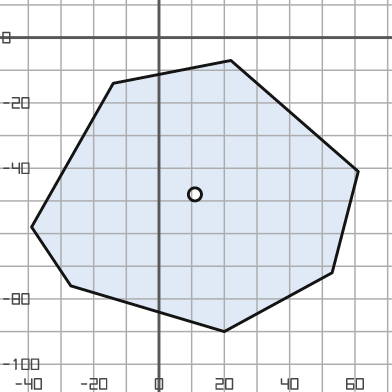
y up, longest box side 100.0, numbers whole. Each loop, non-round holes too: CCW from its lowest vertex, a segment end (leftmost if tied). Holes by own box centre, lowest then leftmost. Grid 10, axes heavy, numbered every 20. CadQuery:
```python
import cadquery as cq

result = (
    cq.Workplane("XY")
    .moveTo(20.0, -90.0)
    .lineTo(53.0, -72.0)
    .lineTo(61.0, -41.0)
    .lineTo(22.0, -7.0)
    .lineTo(-14.0, -14.0)
    .lineTo(-39.0, -58.0)
    .lineTo(-27.0, -76.0)
    .close()
    .moveTo(11.0, -48.0)
    .circle(2.0)
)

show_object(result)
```